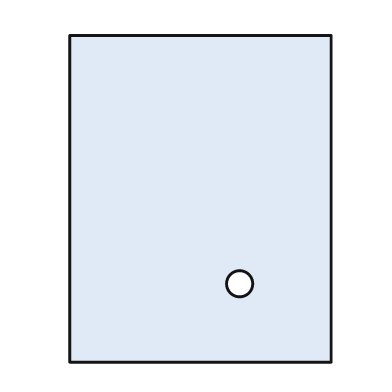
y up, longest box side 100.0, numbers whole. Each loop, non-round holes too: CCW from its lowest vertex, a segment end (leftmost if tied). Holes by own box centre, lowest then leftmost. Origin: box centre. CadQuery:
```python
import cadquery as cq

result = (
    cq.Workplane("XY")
    .moveTo(-40.0, -50.0)
    .lineTo(40.0, -50.0)
    .lineTo(40.0, 50.0)
    .lineTo(-40.0, 50.0)
    .close()
    .moveTo(12.0, -26.0)
    .circle(4.0)
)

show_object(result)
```